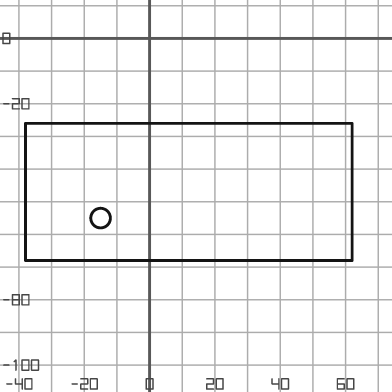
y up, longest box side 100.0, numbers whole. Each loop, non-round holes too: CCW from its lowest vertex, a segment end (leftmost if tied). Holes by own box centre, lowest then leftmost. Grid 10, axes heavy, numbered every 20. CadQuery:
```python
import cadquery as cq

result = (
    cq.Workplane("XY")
    .moveTo(-38.0, -68.0)
    .lineTo(62.0, -68.0)
    .lineTo(62.0, -26.0)
    .lineTo(-38.0, -26.0)
    .close()
    .moveTo(-15.0, -55.0)
    .circle(3.0)
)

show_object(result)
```